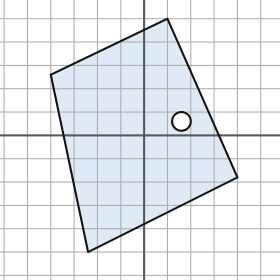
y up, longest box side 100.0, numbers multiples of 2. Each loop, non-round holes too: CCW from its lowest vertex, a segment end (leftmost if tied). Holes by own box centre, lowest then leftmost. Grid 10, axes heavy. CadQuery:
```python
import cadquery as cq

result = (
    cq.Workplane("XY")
    .moveTo(-24.0, -50.0)
    .lineTo(40.0, -18.0)
    .lineTo(10.0, 50.0)
    .lineTo(-40.0, 26.0)
    .close()
    .moveTo(16.0, 6.0)
    .circle(4.0)
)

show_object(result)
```